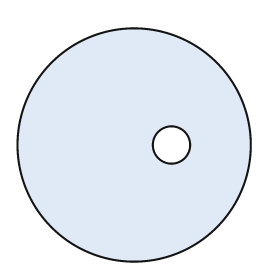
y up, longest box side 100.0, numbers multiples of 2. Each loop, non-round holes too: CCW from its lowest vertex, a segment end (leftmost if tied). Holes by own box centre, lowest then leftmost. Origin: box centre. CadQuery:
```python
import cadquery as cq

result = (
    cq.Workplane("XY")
    .moveTo(0.0, 0.0)
    .circle(50.0)
    .moveTo(16.0, 0.0)
    .circle(8.0)
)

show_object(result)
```